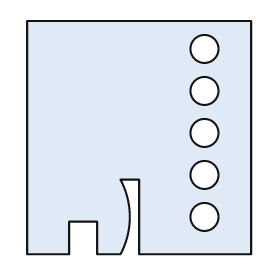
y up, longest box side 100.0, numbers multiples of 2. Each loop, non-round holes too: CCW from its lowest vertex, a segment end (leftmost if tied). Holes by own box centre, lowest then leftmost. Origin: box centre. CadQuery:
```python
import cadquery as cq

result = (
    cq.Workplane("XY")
    .moveTo(-48.0, -50.0)
    .lineTo(-30.0, -50.0)
    .lineTo(-30.0, -36.0)
    .lineTo(-18.0, -36.0)
    .lineTo(-18.0, -50.0)
    .lineTo(-8.0, -50.0)
    .threePointArc((-4.0, -34.0), (-8.0, -18.0))
    .lineTo(0.0, -18.0)
    .lineTo(0.0, -50.0)
    .lineTo(48.0, -50.0)
    .lineTo(48.0, 50.0)
    .lineTo(-48.0, 50.0)
    .close()
    .moveTo(28.0, -34.0)
    .circle(6.0)
    .moveTo(28.0, -16.0)
    .circle(6.0)
    .moveTo(28.0, 2.0)
    .circle(6.0)
    .moveTo(28.0, 20.0)
    .circle(6.0)
    .moveTo(28.0, 38.0)
    .circle(6.0)
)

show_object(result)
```